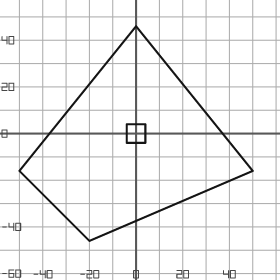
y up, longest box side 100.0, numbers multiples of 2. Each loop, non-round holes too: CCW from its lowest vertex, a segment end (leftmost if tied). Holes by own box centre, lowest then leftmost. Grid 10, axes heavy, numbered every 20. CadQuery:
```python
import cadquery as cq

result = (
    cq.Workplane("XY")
    .moveTo(-20.0, -46.0)
    .lineTo(50.0, -16.0)
    .lineTo(0.0, 46.0)
    .lineTo(-50.0, -16.0)
    .close()
    .moveTo(-4.0, -4.0)
    .lineTo(4.0, -4.0)
    .lineTo(4.0, 4.0)
    .lineTo(-4.0, 4.0)
    .close()
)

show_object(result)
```